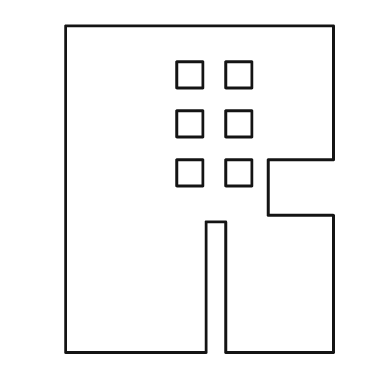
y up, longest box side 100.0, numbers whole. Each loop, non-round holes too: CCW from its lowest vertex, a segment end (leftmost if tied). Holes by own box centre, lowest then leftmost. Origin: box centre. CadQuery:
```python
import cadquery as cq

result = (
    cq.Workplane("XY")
    .moveTo(-41.0, -50.0)
    .lineTo(2.0, -50.0)
    .lineTo(2.0, -10.0)
    .lineTo(8.0, -10.0)
    .lineTo(8.0, -50.0)
    .lineTo(41.0, -50.0)
    .lineTo(41.0, -8.0)
    .lineTo(21.0, -8.0)
    .lineTo(21.0, 9.0)
    .lineTo(41.0, 9.0)
    .lineTo(41.0, 50.0)
    .lineTo(-41.0, 50.0)
    .close()
    .moveTo(-7.0, 1.0)
    .lineTo(1.0, 1.0)
    .lineTo(1.0, 9.0)
    .lineTo(-7.0, 9.0)
    .close()
    .moveTo(8.0, 1.0)
    .lineTo(16.0, 1.0)
    .lineTo(16.0, 9.0)
    .lineTo(8.0, 9.0)
    .close()
    .moveTo(-7.0, 16.0)
    .lineTo(1.0, 16.0)
    .lineTo(1.0, 24.0)
    .lineTo(-7.0, 24.0)
    .close()
    .moveTo(8.0, 16.0)
    .lineTo(16.0, 16.0)
    .lineTo(16.0, 24.0)
    .lineTo(8.0, 24.0)
    .close()
    .moveTo(-7.0, 31.0)
    .lineTo(1.0, 31.0)
    .lineTo(1.0, 39.0)
    .lineTo(-7.0, 39.0)
    .close()
    .moveTo(8.0, 31.0)
    .lineTo(16.0, 31.0)
    .lineTo(16.0, 39.0)
    .lineTo(8.0, 39.0)
    .close()
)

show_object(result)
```